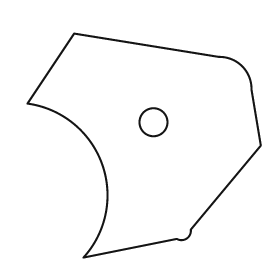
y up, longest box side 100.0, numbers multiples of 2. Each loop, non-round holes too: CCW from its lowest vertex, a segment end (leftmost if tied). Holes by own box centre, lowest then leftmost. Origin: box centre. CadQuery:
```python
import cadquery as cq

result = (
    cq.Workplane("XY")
    .moveTo(-26.0, -48.0)
    .lineTo(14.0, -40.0)
    .threePointArc((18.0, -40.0), (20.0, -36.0))
    .lineTo(50.0, 0.0)
    .lineTo(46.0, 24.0)
    .threePointArc((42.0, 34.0), (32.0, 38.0))
    .lineTo(-30.0, 48.0)
    .lineTo(-50.0, 18.0)
    .threePointArc((-18.0, -8.0), (-26.0, -48.0))
    .close()
    .moveTo(4.0, 10.0)
    .circle(6.0)
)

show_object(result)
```